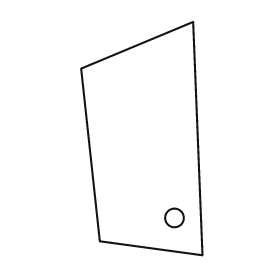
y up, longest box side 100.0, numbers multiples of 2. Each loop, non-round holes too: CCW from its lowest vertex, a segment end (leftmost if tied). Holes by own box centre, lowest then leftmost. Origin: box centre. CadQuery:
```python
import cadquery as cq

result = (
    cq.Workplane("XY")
    .moveTo(26.0, -50.0)
    .lineTo(22.0, 50.0)
    .lineTo(-26.0, 30.0)
    .lineTo(-18.0, -44.0)
    .close()
    .moveTo(14.0, -34.0)
    .circle(4.0)
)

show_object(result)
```